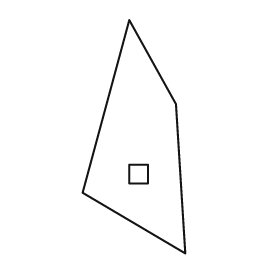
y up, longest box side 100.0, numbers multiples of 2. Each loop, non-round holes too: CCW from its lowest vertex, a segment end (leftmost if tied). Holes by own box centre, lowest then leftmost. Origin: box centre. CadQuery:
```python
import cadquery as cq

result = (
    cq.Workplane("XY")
    .moveTo(22.0, -50.0)
    .lineTo(18.0, 14.0)
    .lineTo(-2.0, 50.0)
    .lineTo(-22.0, -24.0)
    .close()
    .moveTo(-2.0, -20.0)
    .lineTo(6.0, -20.0)
    .lineTo(6.0, -12.0)
    .lineTo(-2.0, -12.0)
    .close()
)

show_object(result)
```